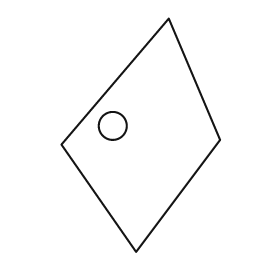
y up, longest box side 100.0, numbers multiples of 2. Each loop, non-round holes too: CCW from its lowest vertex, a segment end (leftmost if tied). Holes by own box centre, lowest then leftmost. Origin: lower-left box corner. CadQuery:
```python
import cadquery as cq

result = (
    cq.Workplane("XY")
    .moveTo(32.0, 0.0)
    .lineTo(68.0, 48.0)
    .lineTo(46.0, 100.0)
    .lineTo(0.0, 46.0)
    .close()
    .moveTo(22.0, 54.0)
    .circle(6.0)
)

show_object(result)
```